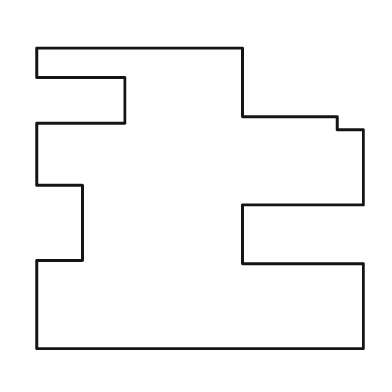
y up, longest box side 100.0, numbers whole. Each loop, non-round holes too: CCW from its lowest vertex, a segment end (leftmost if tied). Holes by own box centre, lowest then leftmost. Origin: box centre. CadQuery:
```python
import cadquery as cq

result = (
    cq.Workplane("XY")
    .moveTo(-50.0, -46.0)
    .lineTo(50.0, -46.0)
    .lineTo(50.0, -20.0)
    .lineTo(13.0, -20.0)
    .lineTo(13.0, -2.0)
    .lineTo(50.0, -2.0)
    .lineTo(50.0, 21.0)
    .lineTo(42.0, 21.0)
    .lineTo(42.0, 25.0)
    .lineTo(13.0, 25.0)
    .lineTo(13.0, 46.0)
    .lineTo(-50.0, 46.0)
    .lineTo(-50.0, 37.0)
    .lineTo(-23.0, 37.0)
    .lineTo(-23.0, 23.0)
    .lineTo(-50.0, 23.0)
    .lineTo(-50.0, 4.0)
    .lineTo(-36.0, 4.0)
    .lineTo(-36.0, -19.0)
    .lineTo(-50.0, -19.0)
    .close()
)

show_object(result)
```